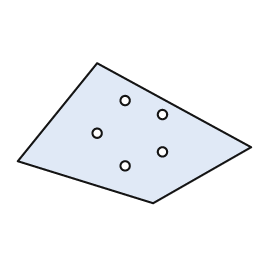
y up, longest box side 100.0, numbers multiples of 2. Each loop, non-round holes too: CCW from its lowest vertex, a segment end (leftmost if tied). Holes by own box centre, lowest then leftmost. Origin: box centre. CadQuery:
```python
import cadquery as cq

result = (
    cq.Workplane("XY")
    .moveTo(8.0, -30.0)
    .lineTo(50.0, -6.0)
    .lineTo(-16.0, 30.0)
    .lineTo(-50.0, -12.0)
    .close()
    .moveTo(-4.0, -14.0)
    .circle(2.0)
    .moveTo(12.0, -8.0)
    .circle(2.0)
    .moveTo(-16.0, 0.0)
    .circle(2.0)
    .moveTo(12.0, 8.0)
    .circle(2.0)
    .moveTo(-4.0, 14.0)
    .circle(2.0)
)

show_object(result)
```